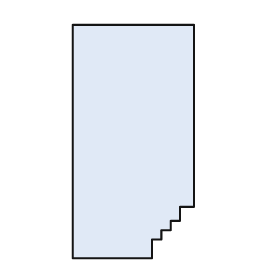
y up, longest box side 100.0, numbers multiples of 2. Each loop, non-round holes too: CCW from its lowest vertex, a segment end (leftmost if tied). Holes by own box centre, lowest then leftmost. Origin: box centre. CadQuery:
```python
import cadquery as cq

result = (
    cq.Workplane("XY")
    .moveTo(-26.0, -50.0)
    .lineTo(8.0, -50.0)
    .lineTo(8.0, -42.0)
    .lineTo(12.0, -42.0)
    .lineTo(12.0, -38.0)
    .lineTo(16.0, -38.0)
    .lineTo(16.0, -34.0)
    .lineTo(20.0, -34.0)
    .lineTo(20.0, -28.0)
    .lineTo(26.0, -28.0)
    .lineTo(26.0, 50.0)
    .lineTo(-26.0, 50.0)
    .close()
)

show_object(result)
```